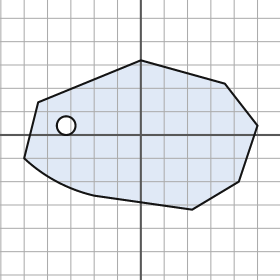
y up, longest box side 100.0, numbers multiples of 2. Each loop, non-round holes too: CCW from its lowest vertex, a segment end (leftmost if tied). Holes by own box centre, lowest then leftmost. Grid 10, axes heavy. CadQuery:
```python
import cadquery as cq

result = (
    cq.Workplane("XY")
    .moveTo(22.0, -32.0)
    .lineTo(42.0, -20.0)
    .lineTo(50.0, 4.0)
    .lineTo(36.0, 22.0)
    .lineTo(0.0, 32.0)
    .lineTo(-44.0, 14.0)
    .lineTo(-50.0, -10.0)
    .threePointArc((-36.0, -20.0), (-20.0, -26.0))
    .close()
    .moveTo(-32.0, 4.0)
    .circle(4.0)
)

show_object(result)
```